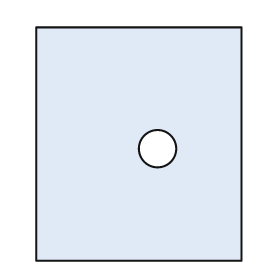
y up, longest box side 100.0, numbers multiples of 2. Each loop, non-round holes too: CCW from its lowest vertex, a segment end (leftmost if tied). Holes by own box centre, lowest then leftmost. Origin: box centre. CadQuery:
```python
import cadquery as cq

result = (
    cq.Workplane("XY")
    .moveTo(-44.0, -50.0)
    .lineTo(44.0, -50.0)
    .lineTo(44.0, 50.0)
    .lineTo(-44.0, 50.0)
    .close()
    .moveTo(8.0, -2.0)
    .circle(8.0)
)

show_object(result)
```